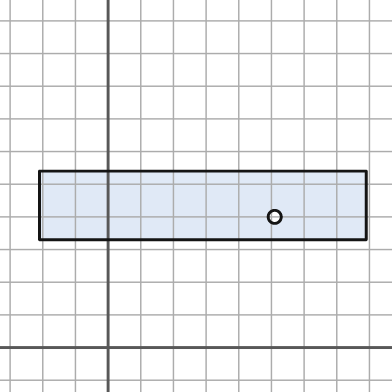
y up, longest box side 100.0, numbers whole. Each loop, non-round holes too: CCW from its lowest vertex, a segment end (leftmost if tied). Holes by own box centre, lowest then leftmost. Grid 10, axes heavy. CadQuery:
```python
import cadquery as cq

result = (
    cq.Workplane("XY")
    .moveTo(-21.0, 33.0)
    .lineTo(79.0, 33.0)
    .lineTo(79.0, 54.0)
    .lineTo(-21.0, 54.0)
    .close()
    .moveTo(51.0, 40.0)
    .circle(2.0)
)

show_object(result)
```